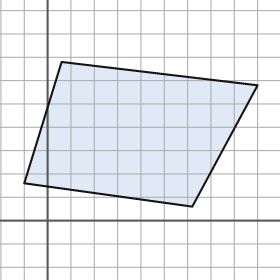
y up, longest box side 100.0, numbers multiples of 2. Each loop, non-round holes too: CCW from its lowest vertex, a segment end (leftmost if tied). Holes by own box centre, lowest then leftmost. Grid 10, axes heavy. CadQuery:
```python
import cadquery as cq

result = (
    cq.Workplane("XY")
    .moveTo(62.0, 6.0)
    .lineTo(90.0, 58.0)
    .lineTo(6.0, 68.0)
    .lineTo(-10.0, 16.0)
    .close()
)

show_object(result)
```